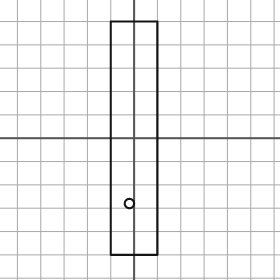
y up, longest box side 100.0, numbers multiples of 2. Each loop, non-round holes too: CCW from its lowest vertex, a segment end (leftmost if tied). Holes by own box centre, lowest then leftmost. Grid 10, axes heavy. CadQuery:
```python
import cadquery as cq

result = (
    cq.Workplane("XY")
    .moveTo(-10.0, -50.0)
    .lineTo(10.0, -50.0)
    .lineTo(10.0, 50.0)
    .lineTo(-10.0, 50.0)
    .close()
    .moveTo(-2.0, -28.0)
    .circle(2.0)
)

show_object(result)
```